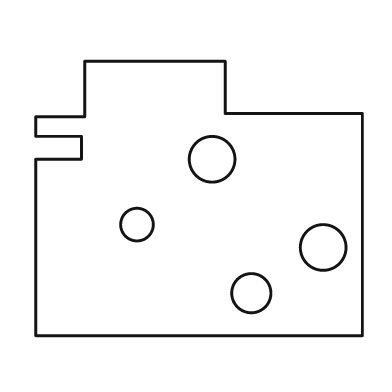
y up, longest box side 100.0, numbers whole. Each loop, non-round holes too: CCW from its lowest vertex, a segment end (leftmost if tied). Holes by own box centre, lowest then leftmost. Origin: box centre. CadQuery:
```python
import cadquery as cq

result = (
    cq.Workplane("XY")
    .moveTo(-50.0, -42.0)
    .lineTo(50.0, -42.0)
    .lineTo(50.0, 26.0)
    .lineTo(8.0, 26.0)
    .lineTo(8.0, 42.0)
    .lineTo(-35.0, 42.0)
    .lineTo(-35.0, 25.0)
    .lineTo(-50.0, 25.0)
    .lineTo(-50.0, 19.0)
    .lineTo(-36.0, 19.0)
    .lineTo(-36.0, 12.0)
    .lineTo(-50.0, 12.0)
    .close()
    .moveTo(16.0, -29.0)
    .circle(6.0)
    .moveTo(38.0, -15.0)
    .circle(7.0)
    .moveTo(-19.0, -8.0)
    .circle(5.0)
    .moveTo(4.0, 12.0)
    .circle(7.0)
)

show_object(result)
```